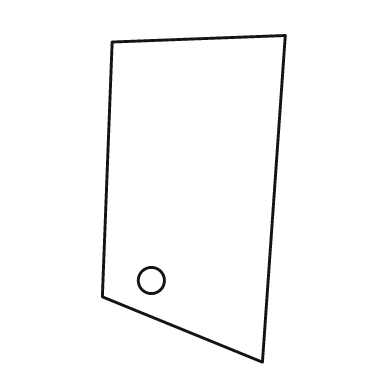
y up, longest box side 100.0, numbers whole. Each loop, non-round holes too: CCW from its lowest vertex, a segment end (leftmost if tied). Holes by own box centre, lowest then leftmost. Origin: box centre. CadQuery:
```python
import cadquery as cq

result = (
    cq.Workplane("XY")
    .moveTo(21.0, -50.0)
    .lineTo(28.0, 50.0)
    .lineTo(-25.0, 48.0)
    .lineTo(-28.0, -30.0)
    .close()
    .moveTo(-13.0, -25.0)
    .circle(4.0)
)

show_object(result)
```